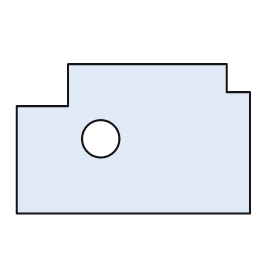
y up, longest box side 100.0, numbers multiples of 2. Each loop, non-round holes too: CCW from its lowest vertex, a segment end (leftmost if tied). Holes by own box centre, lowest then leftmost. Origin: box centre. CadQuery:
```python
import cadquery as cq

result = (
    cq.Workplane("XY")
    .moveTo(-50.0, -32.0)
    .lineTo(50.0, -32.0)
    .lineTo(50.0, 20.0)
    .lineTo(40.0, 20.0)
    .lineTo(40.0, 32.0)
    .lineTo(-28.0, 32.0)
    .lineTo(-28.0, 14.0)
    .lineTo(-50.0, 14.0)
    .close()
    .moveTo(-14.0, 0.0)
    .circle(8.0)
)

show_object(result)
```